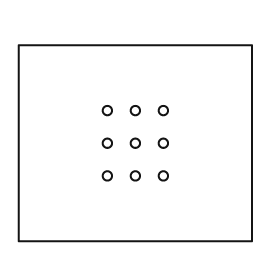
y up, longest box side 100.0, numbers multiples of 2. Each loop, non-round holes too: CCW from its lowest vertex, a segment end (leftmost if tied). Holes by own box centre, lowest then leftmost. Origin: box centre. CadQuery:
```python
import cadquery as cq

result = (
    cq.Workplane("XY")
    .moveTo(-50.0, -42.0)
    .lineTo(50.0, -42.0)
    .lineTo(50.0, 42.0)
    .lineTo(-50.0, 42.0)
    .close()
    .moveTo(-12.0, -14.0)
    .circle(2.0)
    .moveTo(0.0, -14.0)
    .circle(2.0)
    .moveTo(12.0, -14.0)
    .circle(2.0)
    .moveTo(-12.0, 0.0)
    .circle(2.0)
    .moveTo(0.0, 0.0)
    .circle(2.0)
    .moveTo(12.0, 0.0)
    .circle(2.0)
    .moveTo(-12.0, 14.0)
    .circle(2.0)
    .moveTo(0.0, 14.0)
    .circle(2.0)
    .moveTo(12.0, 14.0)
    .circle(2.0)
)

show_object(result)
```